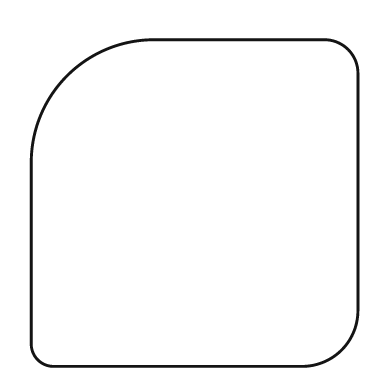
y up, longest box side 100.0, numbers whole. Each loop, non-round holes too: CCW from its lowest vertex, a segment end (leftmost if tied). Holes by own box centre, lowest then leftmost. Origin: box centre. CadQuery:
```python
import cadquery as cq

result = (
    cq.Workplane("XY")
    .moveTo(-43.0, -50.0)
    .lineTo(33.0, -50.0)
    .threePointArc((45.0, -45.0), (50.0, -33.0))
    .lineTo(50.0, 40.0)
    .threePointArc((47.0, 47.0), (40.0, 50.0))
    .lineTo(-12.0, 50.0)
    .threePointArc((-39.0, 39.0), (-50.0, 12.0))
    .lineTo(-50.0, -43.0)
    .threePointArc((-48.0, -48.0), (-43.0, -50.0))
    .close()
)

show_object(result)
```